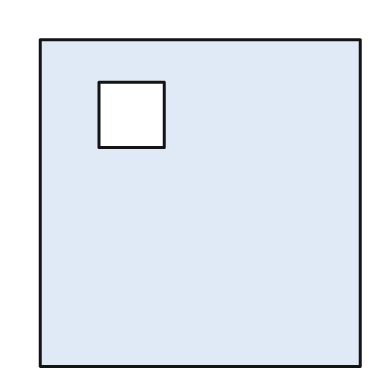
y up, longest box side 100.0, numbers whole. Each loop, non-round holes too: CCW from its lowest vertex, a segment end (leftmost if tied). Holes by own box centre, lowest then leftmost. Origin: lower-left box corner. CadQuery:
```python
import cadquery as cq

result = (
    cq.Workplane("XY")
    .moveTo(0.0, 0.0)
    .lineTo(98.0, 0.0)
    .lineTo(98.0, 100.0)
    .lineTo(0.0, 100.0)
    .close()
    .moveTo(18.0, 67.0)
    .lineTo(38.0, 67.0)
    .lineTo(38.0, 87.0)
    .lineTo(18.0, 87.0)
    .close()
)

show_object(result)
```